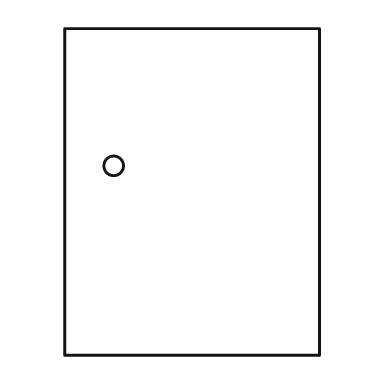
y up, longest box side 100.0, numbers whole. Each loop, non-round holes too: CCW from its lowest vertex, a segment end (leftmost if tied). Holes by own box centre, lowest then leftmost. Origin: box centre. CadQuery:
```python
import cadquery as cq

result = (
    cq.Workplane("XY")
    .moveTo(-39.0, -50.0)
    .lineTo(39.0, -50.0)
    .lineTo(39.0, 50.0)
    .lineTo(-39.0, 50.0)
    .close()
    .moveTo(-24.0, 8.0)
    .circle(3.0)
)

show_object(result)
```